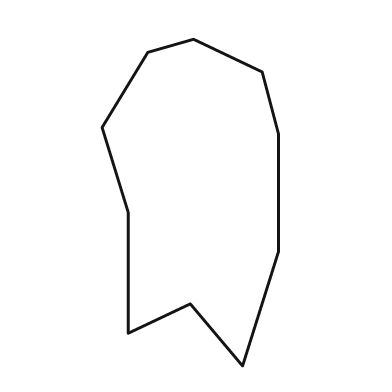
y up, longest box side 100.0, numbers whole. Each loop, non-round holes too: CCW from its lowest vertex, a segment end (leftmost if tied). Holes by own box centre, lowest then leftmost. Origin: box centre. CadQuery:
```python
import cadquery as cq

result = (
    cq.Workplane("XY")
    .moveTo(16.0, -50.0)
    .lineTo(27.0, -15.0)
    .lineTo(27.0, 21.0)
    .lineTo(22.0, 40.0)
    .lineTo(1.0, 50.0)
    .lineTo(-13.0, 46.0)
    .lineTo(-27.0, 23.0)
    .lineTo(-19.0, -3.0)
    .lineTo(-19.0, -40.0)
    .lineTo(0.0, -31.0)
    .close()
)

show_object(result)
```